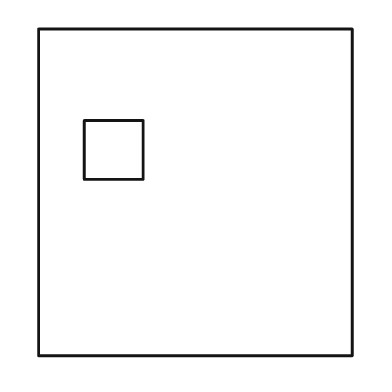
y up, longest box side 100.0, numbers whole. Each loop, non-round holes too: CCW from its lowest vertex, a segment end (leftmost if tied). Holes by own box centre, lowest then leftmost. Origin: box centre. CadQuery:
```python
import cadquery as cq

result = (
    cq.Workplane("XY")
    .moveTo(-48.0, -50.0)
    .lineTo(48.0, -50.0)
    .lineTo(48.0, 50.0)
    .lineTo(-48.0, 50.0)
    .close()
    .moveTo(-34.0, 4.0)
    .lineTo(-16.0, 4.0)
    .lineTo(-16.0, 22.0)
    .lineTo(-34.0, 22.0)
    .close()
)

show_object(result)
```